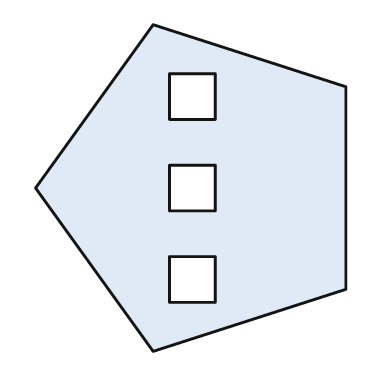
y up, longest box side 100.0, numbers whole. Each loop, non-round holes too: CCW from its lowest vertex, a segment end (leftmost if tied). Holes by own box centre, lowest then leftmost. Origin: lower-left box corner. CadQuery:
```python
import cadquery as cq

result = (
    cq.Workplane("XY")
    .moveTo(36.0, 0.0)
    .lineTo(95.0, 19.0)
    .lineTo(95.0, 81.0)
    .lineTo(36.0, 100.0)
    .lineTo(0.0, 50.0)
    .close()
    .moveTo(41.0, 15.0)
    .lineTo(55.0, 15.0)
    .lineTo(55.0, 29.0)
    .lineTo(41.0, 29.0)
    .close()
    .moveTo(41.0, 43.0)
    .lineTo(55.0, 43.0)
    .lineTo(55.0, 57.0)
    .lineTo(41.0, 57.0)
    .close()
    .moveTo(41.0, 71.0)
    .lineTo(55.0, 71.0)
    .lineTo(55.0, 85.0)
    .lineTo(41.0, 85.0)
    .close()
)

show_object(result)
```